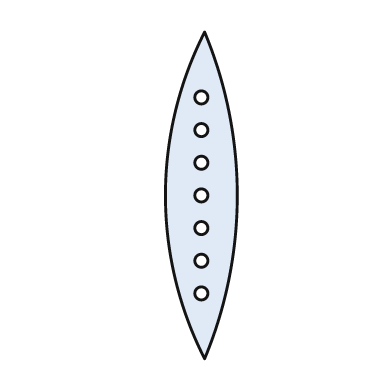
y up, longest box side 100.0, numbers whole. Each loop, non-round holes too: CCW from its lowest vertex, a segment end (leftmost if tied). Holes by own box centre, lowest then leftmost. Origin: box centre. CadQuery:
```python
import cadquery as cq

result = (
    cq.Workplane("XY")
    .moveTo(1.0, -50.0)
    .threePointArc((11.0, 0.0), (1.0, 50.0))
    .threePointArc((-11.0, 0.0), (1.0, -50.0))
    .close()
    .moveTo(0.0, -30.0)
    .circle(2.0)
    .moveTo(0.0, -20.0)
    .circle(2.0)
    .moveTo(0.0, -10.0)
    .circle(2.0)
    .moveTo(0.0, 0.0)
    .circle(2.0)
    .moveTo(0.0, 10.0)
    .circle(2.0)
    .moveTo(0.0, 20.0)
    .circle(2.0)
    .moveTo(0.0, 30.0)
    .circle(2.0)
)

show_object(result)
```